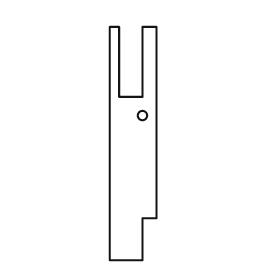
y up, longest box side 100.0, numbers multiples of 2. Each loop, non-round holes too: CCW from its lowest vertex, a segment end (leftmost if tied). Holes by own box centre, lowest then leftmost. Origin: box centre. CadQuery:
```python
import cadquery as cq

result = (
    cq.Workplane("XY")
    .moveTo(-10.0, -50.0)
    .lineTo(4.0, -50.0)
    .lineTo(4.0, -32.0)
    .lineTo(10.0, -32.0)
    .lineTo(10.0, 50.0)
    .lineTo(4.0, 50.0)
    .lineTo(4.0, 20.0)
    .lineTo(-6.0, 20.0)
    .lineTo(-6.0, 50.0)
    .lineTo(-10.0, 50.0)
    .close()
    .moveTo(4.0, 12.0)
    .circle(2.0)
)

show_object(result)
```